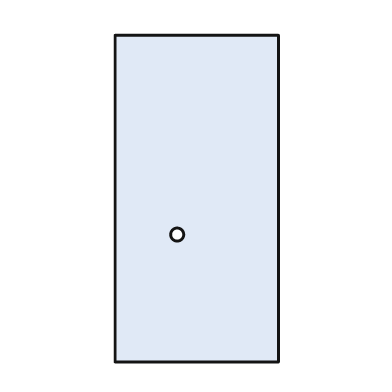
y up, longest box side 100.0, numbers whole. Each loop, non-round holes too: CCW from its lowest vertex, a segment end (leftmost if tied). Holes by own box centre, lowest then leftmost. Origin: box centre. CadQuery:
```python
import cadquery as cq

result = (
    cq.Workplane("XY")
    .moveTo(-25.0, -50.0)
    .lineTo(25.0, -50.0)
    .lineTo(25.0, 50.0)
    .lineTo(-25.0, 50.0)
    .close()
    .moveTo(-6.0, -11.0)
    .circle(2.0)
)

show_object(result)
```